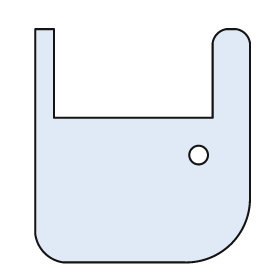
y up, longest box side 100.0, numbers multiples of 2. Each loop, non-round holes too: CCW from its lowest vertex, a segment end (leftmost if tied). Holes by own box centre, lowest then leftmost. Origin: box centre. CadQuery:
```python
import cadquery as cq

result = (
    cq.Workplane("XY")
    .moveTo(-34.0, -50.0)
    .lineTo(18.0, -50.0)
    .threePointArc((38.0, -42.0), (46.0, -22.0))
    .lineTo(46.0, 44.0)
    .threePointArc((44.0, 48.0), (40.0, 50.0))
    .lineTo(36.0, 50.0)
    .threePointArc((32.0, 48.0), (30.0, 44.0))
    .lineTo(30.0, 12.0)
    .lineTo(-38.0, 12.0)
    .lineTo(-38.0, 50.0)
    .lineTo(-46.0, 50.0)
    .lineTo(-46.0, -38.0)
    .threePointArc((-42.0, -46.0), (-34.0, -50.0))
    .close()
    .moveTo(24.0, -4.0)
    .circle(4.0)
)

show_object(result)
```